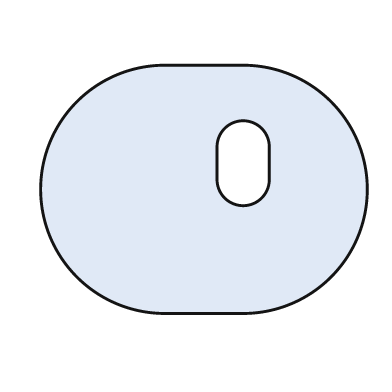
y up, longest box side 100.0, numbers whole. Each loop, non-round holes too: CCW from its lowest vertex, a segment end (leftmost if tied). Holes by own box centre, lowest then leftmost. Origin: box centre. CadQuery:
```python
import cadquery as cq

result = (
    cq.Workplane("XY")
    .moveTo(-12.0, -38.0)
    .lineTo(12.0, -38.0)
    .threePointArc((50.0, 0.0), (12.0, 38.0))
    .lineTo(-12.0, 38.0)
    .threePointArc((-50.0, 0.0), (-12.0, -38.0))
    .close()
    .moveTo(4.0, 3.0)
    .threePointArc((12.0, -5.0), (20.0, 3.0))
    .lineTo(20.0, 13.0)
    .threePointArc((12.0, 21.0), (4.0, 13.0))
    .close()
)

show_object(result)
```